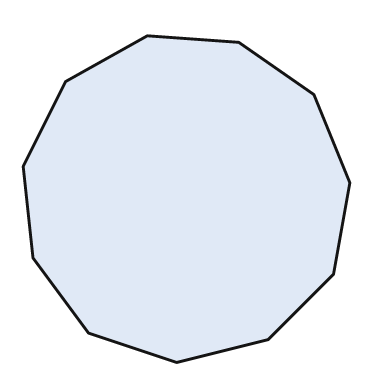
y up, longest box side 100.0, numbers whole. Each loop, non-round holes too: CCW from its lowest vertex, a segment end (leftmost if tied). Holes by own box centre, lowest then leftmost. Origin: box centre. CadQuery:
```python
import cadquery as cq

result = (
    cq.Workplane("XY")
    .moveTo(-3.0, -50.0)
    .lineTo(25.0, -43.0)
    .lineTo(45.0, -23.0)
    .lineTo(50.0, 5.0)
    .lineTo(39.0, 32.0)
    .lineTo(16.0, 48.0)
    .lineTo(-12.0, 50.0)
    .lineTo(-37.0, 36.0)
    .lineTo(-50.0, 10.0)
    .lineTo(-47.0, -18.0)
    .lineTo(-30.0, -41.0)
    .close()
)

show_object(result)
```